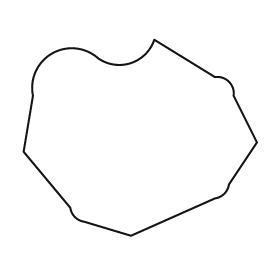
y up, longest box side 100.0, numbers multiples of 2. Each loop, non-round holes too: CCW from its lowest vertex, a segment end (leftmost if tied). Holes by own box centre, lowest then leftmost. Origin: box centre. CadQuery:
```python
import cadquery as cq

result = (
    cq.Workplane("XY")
    .moveTo(-4.0, -42.0)
    .lineTo(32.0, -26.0)
    .threePointArc((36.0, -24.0), (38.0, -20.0))
    .lineTo(50.0, -2.0)
    .lineTo(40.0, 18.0)
    .threePointArc((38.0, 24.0), (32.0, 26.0))
    .lineTo(6.0, 42.0)
    .threePointArc((-4.0, 32.0), (-18.0, 34.0))
    .threePointArc((-38.0, 36.0), (-46.0, 18.0))
    .lineTo(-50.0, -6.0)
    .lineTo(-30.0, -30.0)
    .threePointArc((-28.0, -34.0), (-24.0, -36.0))
    .close()
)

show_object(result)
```